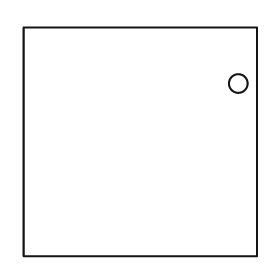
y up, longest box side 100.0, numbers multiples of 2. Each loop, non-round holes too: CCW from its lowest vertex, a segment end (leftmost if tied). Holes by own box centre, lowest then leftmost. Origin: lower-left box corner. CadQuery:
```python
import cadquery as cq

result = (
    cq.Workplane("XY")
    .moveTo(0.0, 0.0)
    .lineTo(100.0, 0.0)
    .lineTo(100.0, 98.0)
    .lineTo(0.0, 98.0)
    .close()
    .moveTo(92.0, 74.0)
    .circle(4.0)
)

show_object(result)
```